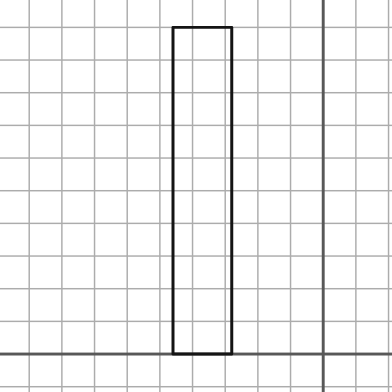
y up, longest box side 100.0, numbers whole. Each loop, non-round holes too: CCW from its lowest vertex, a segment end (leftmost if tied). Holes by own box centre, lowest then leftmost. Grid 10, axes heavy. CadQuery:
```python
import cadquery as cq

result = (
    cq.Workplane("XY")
    .moveTo(-46.0, 0.0)
    .lineTo(-28.0, 0.0)
    .lineTo(-28.0, 100.0)
    .lineTo(-46.0, 100.0)
    .close()
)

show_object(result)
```